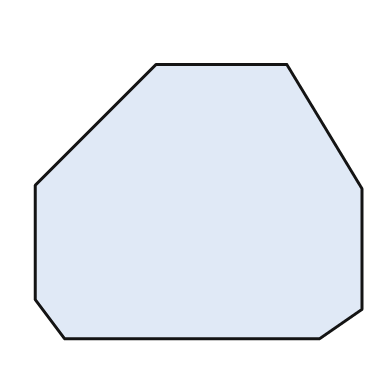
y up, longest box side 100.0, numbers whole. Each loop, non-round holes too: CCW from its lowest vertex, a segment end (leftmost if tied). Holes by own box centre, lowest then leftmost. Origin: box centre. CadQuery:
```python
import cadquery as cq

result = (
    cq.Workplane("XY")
    .moveTo(-41.0, -42.0)
    .lineTo(37.0, -42.0)
    .lineTo(50.0, -33.0)
    .lineTo(50.0, 4.0)
    .lineTo(27.0, 42.0)
    .lineTo(-13.0, 42.0)
    .lineTo(-50.0, 5.0)
    .lineTo(-50.0, -30.0)
    .close()
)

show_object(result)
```